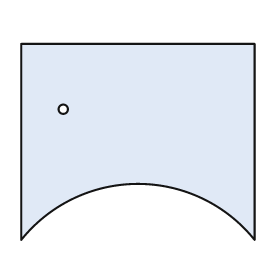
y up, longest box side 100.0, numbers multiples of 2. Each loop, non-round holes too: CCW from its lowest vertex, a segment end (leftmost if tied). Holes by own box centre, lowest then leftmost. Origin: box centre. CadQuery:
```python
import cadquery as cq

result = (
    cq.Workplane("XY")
    .moveTo(-50.0, -42.0)
    .threePointArc((0.0, -18.0), (50.0, -42.0))
    .lineTo(50.0, 42.0)
    .lineTo(-50.0, 42.0)
    .close()
    .moveTo(-32.0, 14.0)
    .circle(2.0)
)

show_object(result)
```